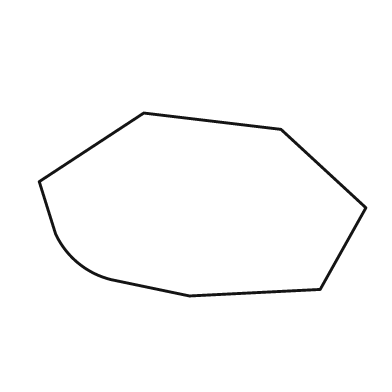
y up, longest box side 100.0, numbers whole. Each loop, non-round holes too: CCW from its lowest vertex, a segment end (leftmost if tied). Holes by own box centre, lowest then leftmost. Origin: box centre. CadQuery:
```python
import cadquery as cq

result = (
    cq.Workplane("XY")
    .moveTo(-4.0, -28.0)
    .lineTo(36.0, -26.0)
    .lineTo(50.0, -1.0)
    .lineTo(24.0, 23.0)
    .lineTo(-18.0, 28.0)
    .lineTo(-50.0, 7.0)
    .lineTo(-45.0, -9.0)
    .threePointArc((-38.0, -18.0), (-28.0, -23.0))
    .close()
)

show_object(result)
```